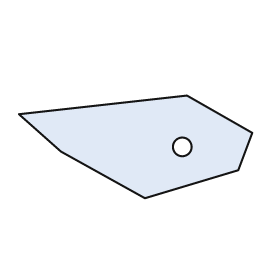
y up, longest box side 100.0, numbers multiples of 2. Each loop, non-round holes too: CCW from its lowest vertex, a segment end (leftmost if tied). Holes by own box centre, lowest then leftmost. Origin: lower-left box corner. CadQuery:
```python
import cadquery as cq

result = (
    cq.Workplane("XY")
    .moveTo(54.0, 0.0)
    .lineTo(94.0, 12.0)
    .lineTo(100.0, 28.0)
    .lineTo(72.0, 44.0)
    .lineTo(0.0, 36.0)
    .lineTo(18.0, 20.0)
    .close()
    .moveTo(70.0, 22.0)
    .circle(4.0)
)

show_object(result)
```